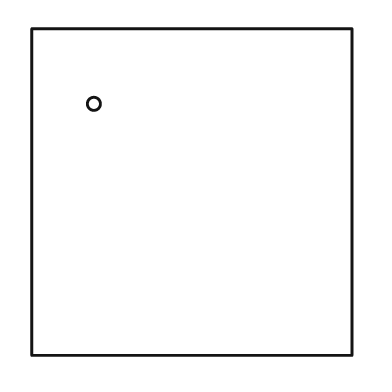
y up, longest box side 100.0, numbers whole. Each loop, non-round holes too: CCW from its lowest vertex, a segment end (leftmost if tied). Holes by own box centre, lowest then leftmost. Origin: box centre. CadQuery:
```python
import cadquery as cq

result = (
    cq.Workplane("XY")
    .moveTo(-49.0, -50.0)
    .lineTo(49.0, -50.0)
    .lineTo(49.0, 50.0)
    .lineTo(-49.0, 50.0)
    .close()
    .moveTo(-30.0, 27.0)
    .circle(2.0)
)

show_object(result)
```